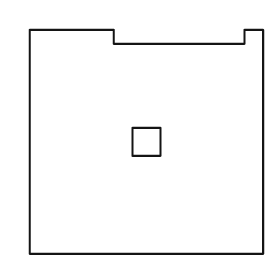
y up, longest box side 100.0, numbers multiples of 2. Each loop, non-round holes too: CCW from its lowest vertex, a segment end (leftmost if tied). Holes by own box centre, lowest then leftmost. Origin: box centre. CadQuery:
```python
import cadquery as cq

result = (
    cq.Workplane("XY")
    .moveTo(-50.0, -48.0)
    .lineTo(50.0, -48.0)
    .lineTo(50.0, 48.0)
    .lineTo(42.0, 48.0)
    .lineTo(42.0, 42.0)
    .lineTo(-14.0, 42.0)
    .lineTo(-14.0, 48.0)
    .lineTo(-50.0, 48.0)
    .close()
    .moveTo(-6.0, -6.0)
    .lineTo(6.0, -6.0)
    .lineTo(6.0, 6.0)
    .lineTo(-6.0, 6.0)
    .close()
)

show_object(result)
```